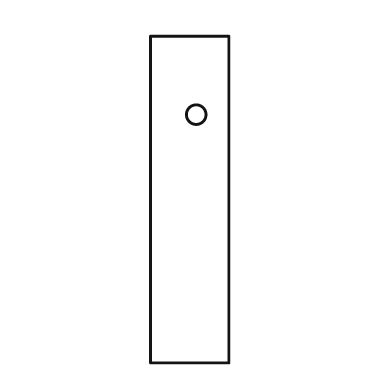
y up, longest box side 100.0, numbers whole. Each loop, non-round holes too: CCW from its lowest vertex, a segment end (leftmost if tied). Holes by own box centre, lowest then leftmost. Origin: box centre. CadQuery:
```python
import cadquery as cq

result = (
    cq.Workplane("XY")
    .moveTo(-12.0, -50.0)
    .lineTo(12.0, -50.0)
    .lineTo(12.0, 50.0)
    .lineTo(-12.0, 50.0)
    .close()
    .moveTo(2.0, 26.0)
    .circle(3.0)
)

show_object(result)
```